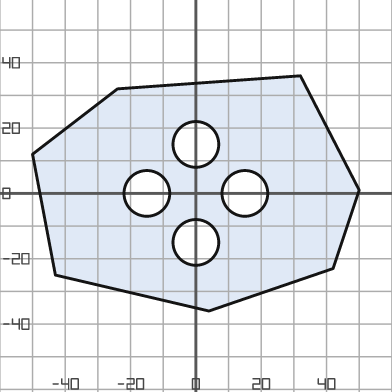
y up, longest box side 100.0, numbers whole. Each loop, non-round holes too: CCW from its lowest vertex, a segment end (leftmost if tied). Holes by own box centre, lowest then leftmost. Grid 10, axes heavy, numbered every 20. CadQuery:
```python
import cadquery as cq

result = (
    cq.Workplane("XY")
    .moveTo(4.0, -36.0)
    .lineTo(42.0, -23.0)
    .lineTo(50.0, 1.0)
    .lineTo(32.0, 36.0)
    .lineTo(-24.0, 32.0)
    .lineTo(-50.0, 12.0)
    .lineTo(-43.0, -25.0)
    .close()
    .moveTo(0.0, -15.0)
    .circle(7.0)
    .moveTo(-15.0, 0.0)
    .circle(7.0)
    .moveTo(15.0, 0.0)
    .circle(7.0)
    .moveTo(0.0, 15.0)
    .circle(7.0)
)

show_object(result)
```